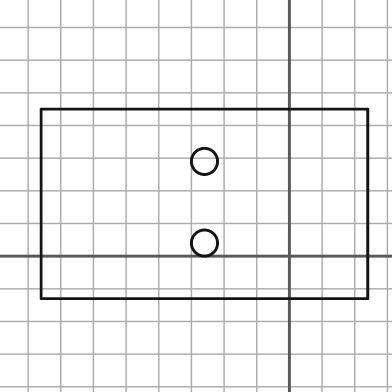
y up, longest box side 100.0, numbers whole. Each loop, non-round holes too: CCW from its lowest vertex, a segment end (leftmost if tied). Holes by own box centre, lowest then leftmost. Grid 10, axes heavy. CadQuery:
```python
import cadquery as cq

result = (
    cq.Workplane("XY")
    .moveTo(-76.0, -13.0)
    .lineTo(24.0, -13.0)
    .lineTo(24.0, 45.0)
    .lineTo(-76.0, 45.0)
    .close()
    .moveTo(-26.0, 4.0)
    .circle(4.0)
    .moveTo(-26.0, 29.0)
    .circle(4.0)
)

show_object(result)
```